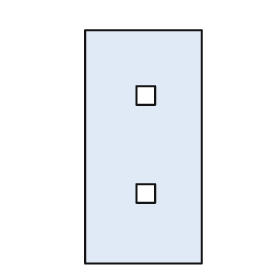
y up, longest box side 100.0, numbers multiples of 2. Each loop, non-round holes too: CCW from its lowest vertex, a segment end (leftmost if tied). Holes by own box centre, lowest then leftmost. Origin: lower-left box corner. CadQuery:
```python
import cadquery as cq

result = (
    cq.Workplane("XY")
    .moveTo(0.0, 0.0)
    .lineTo(50.0, 0.0)
    .lineTo(50.0, 100.0)
    .lineTo(0.0, 100.0)
    .close()
    .moveTo(22.0, 26.0)
    .lineTo(30.0, 26.0)
    .lineTo(30.0, 34.0)
    .lineTo(22.0, 34.0)
    .close()
    .moveTo(22.0, 68.0)
    .lineTo(30.0, 68.0)
    .lineTo(30.0, 76.0)
    .lineTo(22.0, 76.0)
    .close()
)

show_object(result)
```